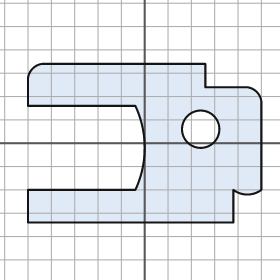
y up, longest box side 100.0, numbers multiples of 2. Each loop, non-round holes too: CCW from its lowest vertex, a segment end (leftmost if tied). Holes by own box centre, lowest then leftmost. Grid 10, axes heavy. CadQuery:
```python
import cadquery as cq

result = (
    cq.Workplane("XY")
    .moveTo(-50.0, -34.0)
    .lineTo(38.0, -34.0)
    .lineTo(38.0, -20.0)
    .threePointArc((44.0, -22.0), (50.0, -20.0))
    .lineTo(50.0, 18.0)
    .threePointArc((48.0, 22.0), (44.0, 24.0))
    .lineTo(26.0, 24.0)
    .lineTo(26.0, 34.0)
    .lineTo(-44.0, 34.0)
    .threePointArc((-48.0, 32.0), (-50.0, 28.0))
    .lineTo(-50.0, 16.0)
    .lineTo(-4.0, 16.0)
    .threePointArc((0.0, -2.0), (-4.0, -20.0))
    .lineTo(-50.0, -20.0)
    .close()
    .moveTo(24.0, 6.0)
    .circle(8.0)
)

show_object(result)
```